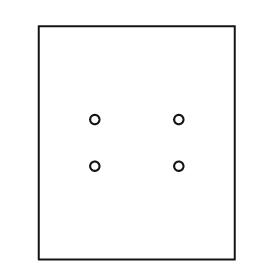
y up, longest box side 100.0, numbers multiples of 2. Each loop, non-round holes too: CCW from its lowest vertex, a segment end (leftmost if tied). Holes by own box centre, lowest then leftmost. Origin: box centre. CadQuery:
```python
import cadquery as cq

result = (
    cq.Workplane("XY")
    .moveTo(-42.0, -50.0)
    .lineTo(42.0, -50.0)
    .lineTo(42.0, 50.0)
    .lineTo(-42.0, 50.0)
    .close()
    .moveTo(-18.0, -10.0)
    .circle(2.0)
    .moveTo(18.0, -10.0)
    .circle(2.0)
    .moveTo(-18.0, 10.0)
    .circle(2.0)
    .moveTo(18.0, 10.0)
    .circle(2.0)
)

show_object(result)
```